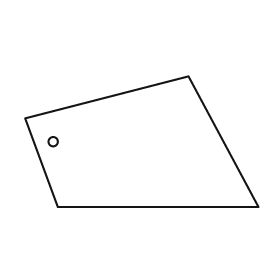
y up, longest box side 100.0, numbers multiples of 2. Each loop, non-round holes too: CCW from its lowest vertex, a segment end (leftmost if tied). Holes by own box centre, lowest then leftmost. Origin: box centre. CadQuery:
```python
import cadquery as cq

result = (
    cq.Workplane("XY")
    .moveTo(-36.0, -28.0)
    .lineTo(50.0, -28.0)
    .lineTo(20.0, 28.0)
    .lineTo(-50.0, 10.0)
    .close()
    .moveTo(-38.0, 0.0)
    .circle(2.0)
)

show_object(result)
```